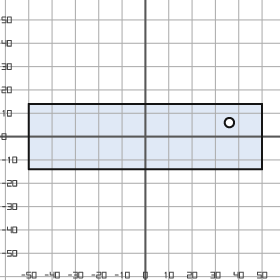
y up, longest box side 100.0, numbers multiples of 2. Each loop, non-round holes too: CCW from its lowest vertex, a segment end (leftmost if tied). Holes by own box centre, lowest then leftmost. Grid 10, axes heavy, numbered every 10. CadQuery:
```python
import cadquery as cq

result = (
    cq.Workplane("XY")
    .moveTo(-50.0, -14.0)
    .lineTo(50.0, -14.0)
    .lineTo(50.0, 14.0)
    .lineTo(-50.0, 14.0)
    .close()
    .moveTo(36.0, 6.0)
    .circle(2.0)
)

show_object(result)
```